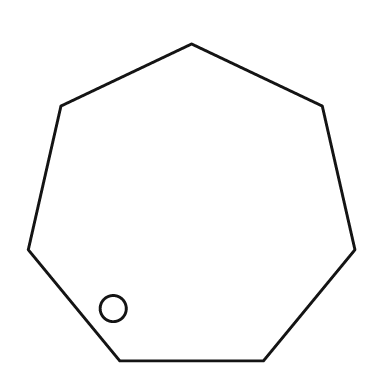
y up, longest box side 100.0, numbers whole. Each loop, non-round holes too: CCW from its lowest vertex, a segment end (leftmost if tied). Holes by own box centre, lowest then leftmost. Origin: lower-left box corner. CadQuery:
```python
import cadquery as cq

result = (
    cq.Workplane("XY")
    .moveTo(28.0, 0.0)
    .lineTo(72.0, 0.0)
    .lineTo(100.0, 34.0)
    .lineTo(90.0, 78.0)
    .lineTo(50.0, 97.0)
    .lineTo(10.0, 78.0)
    .lineTo(0.0, 34.0)
    .close()
    .moveTo(26.0, 16.0)
    .circle(4.0)
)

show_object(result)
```